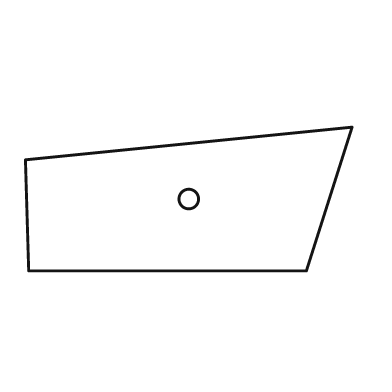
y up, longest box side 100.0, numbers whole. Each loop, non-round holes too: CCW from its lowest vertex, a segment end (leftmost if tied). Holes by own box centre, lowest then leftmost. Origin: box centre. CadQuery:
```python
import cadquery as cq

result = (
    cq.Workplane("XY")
    .moveTo(-49.0, -22.0)
    .lineTo(36.0, -22.0)
    .lineTo(50.0, 22.0)
    .lineTo(-50.0, 12.0)
    .close()
    .moveTo(0.0, 0.0)
    .circle(3.0)
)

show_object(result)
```